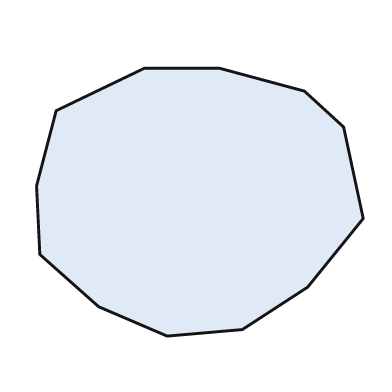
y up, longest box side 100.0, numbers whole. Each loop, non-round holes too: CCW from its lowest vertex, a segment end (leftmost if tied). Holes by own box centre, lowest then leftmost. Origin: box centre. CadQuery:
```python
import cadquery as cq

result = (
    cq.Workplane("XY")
    .moveTo(-10.0, -41.0)
    .lineTo(13.0, -39.0)
    .lineTo(33.0, -26.0)
    .lineTo(50.0, -5.0)
    .lineTo(44.0, 23.0)
    .lineTo(32.0, 34.0)
    .lineTo(6.0, 41.0)
    .lineTo(-17.0, 41.0)
    .lineTo(-44.0, 28.0)
    .lineTo(-50.0, 5.0)
    .lineTo(-49.0, -16.0)
    .lineTo(-31.0, -32.0)
    .close()
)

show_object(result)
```